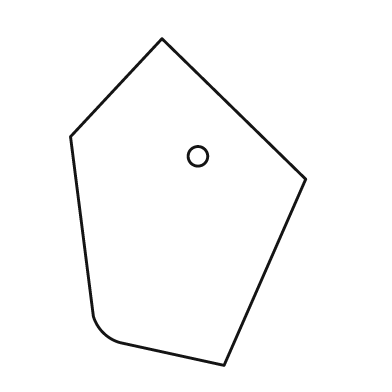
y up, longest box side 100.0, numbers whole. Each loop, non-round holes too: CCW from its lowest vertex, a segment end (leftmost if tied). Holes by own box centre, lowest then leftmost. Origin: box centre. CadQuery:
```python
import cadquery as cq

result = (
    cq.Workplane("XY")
    .moveTo(11.0, -50.0)
    .lineTo(36.0, 7.0)
    .lineTo(-8.0, 50.0)
    .lineTo(-36.0, 20.0)
    .lineTo(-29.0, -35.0)
    .threePointArc((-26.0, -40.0), (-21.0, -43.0))
    .close()
    .moveTo(3.0, 14.0)
    .circle(3.0)
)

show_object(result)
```